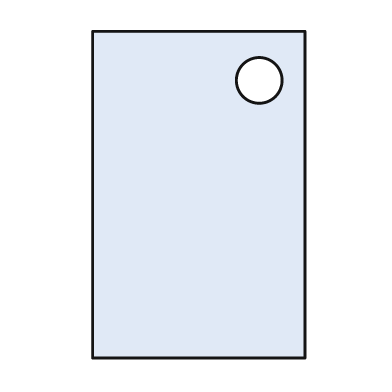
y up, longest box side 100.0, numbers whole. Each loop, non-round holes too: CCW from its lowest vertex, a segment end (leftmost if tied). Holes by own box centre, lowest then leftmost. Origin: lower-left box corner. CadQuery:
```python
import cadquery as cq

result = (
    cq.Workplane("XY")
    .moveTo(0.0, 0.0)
    .lineTo(65.0, 0.0)
    .lineTo(65.0, 100.0)
    .lineTo(0.0, 100.0)
    .close()
    .moveTo(51.0, 85.0)
    .circle(7.0)
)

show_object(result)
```